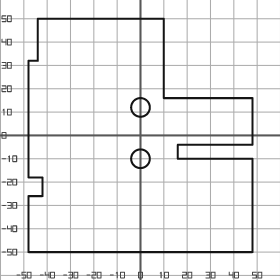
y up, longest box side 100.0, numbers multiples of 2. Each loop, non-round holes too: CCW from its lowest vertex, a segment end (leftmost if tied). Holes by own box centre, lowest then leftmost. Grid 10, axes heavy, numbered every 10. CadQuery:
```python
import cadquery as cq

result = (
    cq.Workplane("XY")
    .moveTo(-48.0, -50.0)
    .lineTo(48.0, -50.0)
    .lineTo(48.0, -10.0)
    .lineTo(16.0, -10.0)
    .lineTo(16.0, -4.0)
    .lineTo(48.0, -4.0)
    .lineTo(48.0, 16.0)
    .lineTo(10.0, 16.0)
    .lineTo(10.0, 50.0)
    .lineTo(-44.0, 50.0)
    .lineTo(-44.0, 32.0)
    .lineTo(-48.0, 32.0)
    .lineTo(-48.0, -18.0)
    .lineTo(-42.0, -18.0)
    .lineTo(-42.0, -26.0)
    .lineTo(-48.0, -26.0)
    .close()
    .moveTo(0.0, -10.0)
    .circle(4.0)
    .moveTo(0.0, 12.0)
    .circle(4.0)
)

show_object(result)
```